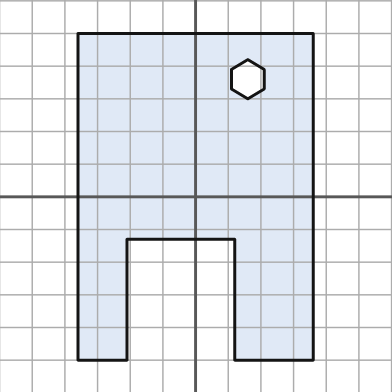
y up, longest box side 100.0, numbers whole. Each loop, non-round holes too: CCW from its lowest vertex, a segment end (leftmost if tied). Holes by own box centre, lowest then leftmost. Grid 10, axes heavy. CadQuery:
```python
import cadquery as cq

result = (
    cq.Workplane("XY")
    .moveTo(-36.0, -50.0)
    .lineTo(-21.0, -50.0)
    .lineTo(-21.0, -13.0)
    .lineTo(12.0, -13.0)
    .lineTo(12.0, -50.0)
    .lineTo(36.0, -50.0)
    .lineTo(36.0, 50.0)
    .lineTo(-36.0, 50.0)
    .close()
    .moveTo(16.0, 30.0)
    .lineTo(21.0, 33.0)
    .lineTo(21.0, 39.0)
    .lineTo(16.0, 42.0)
    .lineTo(11.0, 39.0)
    .lineTo(11.0, 33.0)
    .close()
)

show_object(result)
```